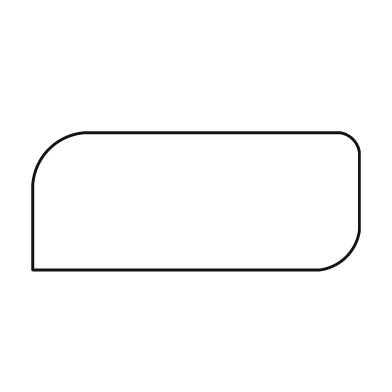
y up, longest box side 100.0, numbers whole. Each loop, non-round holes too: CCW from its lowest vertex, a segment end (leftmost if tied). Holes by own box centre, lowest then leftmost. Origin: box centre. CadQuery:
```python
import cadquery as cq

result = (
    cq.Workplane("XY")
    .moveTo(-50.0, -21.0)
    .lineTo(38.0, -21.0)
    .threePointArc((46.0, -17.0), (50.0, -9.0))
    .lineTo(50.0, 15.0)
    .threePointArc((48.0, 19.0), (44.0, 21.0))
    .lineTo(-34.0, 21.0)
    .threePointArc((-45.0, 16.0), (-50.0, 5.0))
    .close()
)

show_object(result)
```